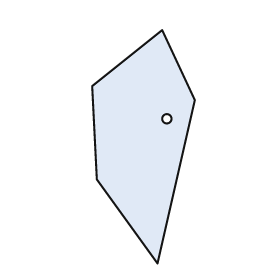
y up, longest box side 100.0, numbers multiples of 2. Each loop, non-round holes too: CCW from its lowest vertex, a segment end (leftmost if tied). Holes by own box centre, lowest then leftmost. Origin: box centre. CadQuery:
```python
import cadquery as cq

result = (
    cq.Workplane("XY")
    .moveTo(6.0, -50.0)
    .lineTo(22.0, 20.0)
    .lineTo(8.0, 50.0)
    .lineTo(-22.0, 26.0)
    .lineTo(-20.0, -14.0)
    .close()
    .moveTo(10.0, 12.0)
    .circle(2.0)
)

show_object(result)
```